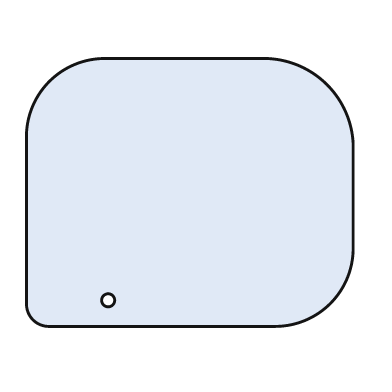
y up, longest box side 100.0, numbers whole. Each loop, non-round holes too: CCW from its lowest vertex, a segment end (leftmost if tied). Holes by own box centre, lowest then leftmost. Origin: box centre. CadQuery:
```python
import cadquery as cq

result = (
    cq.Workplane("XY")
    .moveTo(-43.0, -41.0)
    .lineTo(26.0, -41.0)
    .threePointArc((43.0, -34.0), (50.0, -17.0))
    .lineTo(50.0, 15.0)
    .threePointArc((42.0, 33.0), (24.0, 41.0))
    .lineTo(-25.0, 41.0)
    .threePointArc((-43.0, 34.0), (-50.0, 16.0))
    .lineTo(-50.0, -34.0)
    .threePointArc((-48.0, -39.0), (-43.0, -41.0))
    .close()
    .moveTo(-25.0, -33.0)
    .circle(2.0)
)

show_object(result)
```